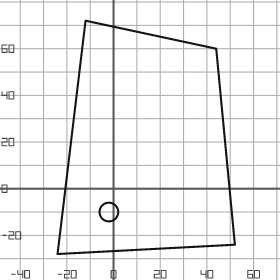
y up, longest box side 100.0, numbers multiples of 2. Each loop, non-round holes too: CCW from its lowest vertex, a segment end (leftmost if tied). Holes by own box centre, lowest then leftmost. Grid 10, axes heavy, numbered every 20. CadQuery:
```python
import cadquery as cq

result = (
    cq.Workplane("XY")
    .moveTo(-24.0, -28.0)
    .lineTo(52.0, -24.0)
    .lineTo(44.0, 60.0)
    .lineTo(-12.0, 72.0)
    .close()
    .moveTo(-2.0, -10.0)
    .circle(4.0)
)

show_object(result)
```